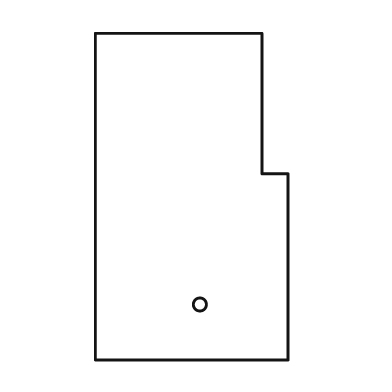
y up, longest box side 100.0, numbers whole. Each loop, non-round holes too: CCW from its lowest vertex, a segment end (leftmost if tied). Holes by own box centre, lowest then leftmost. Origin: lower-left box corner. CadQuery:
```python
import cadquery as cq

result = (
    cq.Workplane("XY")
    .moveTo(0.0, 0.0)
    .lineTo(59.0, 0.0)
    .lineTo(59.0, 57.0)
    .lineTo(51.0, 57.0)
    .lineTo(51.0, 100.0)
    .lineTo(0.0, 100.0)
    .close()
    .moveTo(32.0, 17.0)
    .circle(2.0)
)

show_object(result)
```